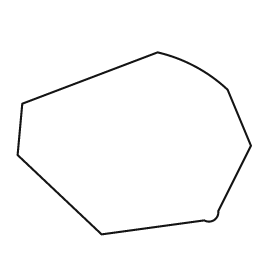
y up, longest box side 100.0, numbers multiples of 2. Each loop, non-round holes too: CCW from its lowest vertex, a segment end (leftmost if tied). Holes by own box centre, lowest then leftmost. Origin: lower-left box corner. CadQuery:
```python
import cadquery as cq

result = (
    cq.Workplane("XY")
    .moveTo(36.0, 0.0)
    .lineTo(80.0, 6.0)
    .threePointArc((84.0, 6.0), (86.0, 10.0))
    .lineTo(100.0, 38.0)
    .lineTo(90.0, 62.0)
    .threePointArc((76.0, 72.0), (60.0, 78.0))
    .lineTo(2.0, 56.0)
    .lineTo(0.0, 34.0)
    .close()
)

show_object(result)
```